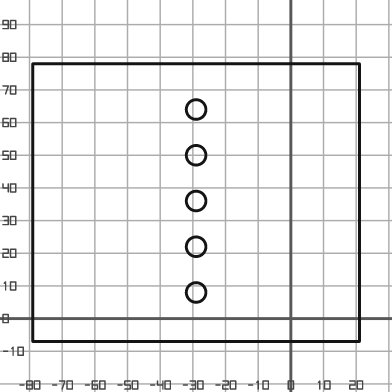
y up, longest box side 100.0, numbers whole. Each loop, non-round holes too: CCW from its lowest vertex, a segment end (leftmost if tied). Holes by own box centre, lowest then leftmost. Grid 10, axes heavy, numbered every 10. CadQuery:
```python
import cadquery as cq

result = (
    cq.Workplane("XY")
    .moveTo(-79.0, -7.0)
    .lineTo(21.0, -7.0)
    .lineTo(21.0, 78.0)
    .lineTo(-79.0, 78.0)
    .close()
    .moveTo(-29.0, 8.0)
    .circle(3.0)
    .moveTo(-29.0, 22.0)
    .circle(3.0)
    .moveTo(-29.0, 36.0)
    .circle(3.0)
    .moveTo(-29.0, 50.0)
    .circle(3.0)
    .moveTo(-29.0, 64.0)
    .circle(3.0)
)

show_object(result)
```